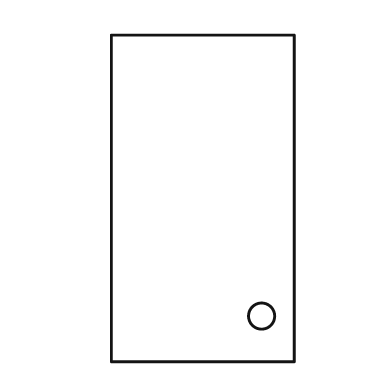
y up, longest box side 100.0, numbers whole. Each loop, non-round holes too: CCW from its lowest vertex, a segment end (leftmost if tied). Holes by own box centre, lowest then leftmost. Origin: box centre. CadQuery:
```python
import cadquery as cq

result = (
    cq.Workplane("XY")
    .moveTo(-28.0, -50.0)
    .lineTo(28.0, -50.0)
    .lineTo(28.0, 50.0)
    .lineTo(-28.0, 50.0)
    .close()
    .moveTo(18.0, -36.0)
    .circle(4.0)
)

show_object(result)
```